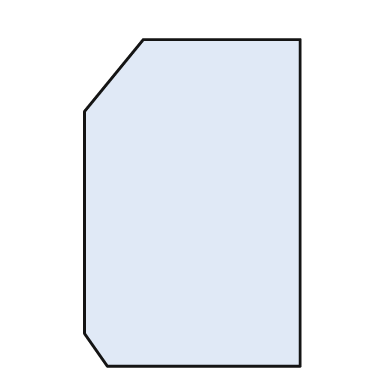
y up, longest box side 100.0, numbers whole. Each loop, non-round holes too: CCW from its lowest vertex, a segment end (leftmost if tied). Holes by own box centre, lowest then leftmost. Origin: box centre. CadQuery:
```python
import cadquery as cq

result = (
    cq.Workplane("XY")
    .moveTo(-26.0, -50.0)
    .lineTo(33.0, -50.0)
    .lineTo(33.0, 50.0)
    .lineTo(-15.0, 50.0)
    .lineTo(-33.0, 28.0)
    .lineTo(-33.0, -40.0)
    .close()
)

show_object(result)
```